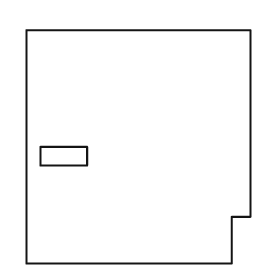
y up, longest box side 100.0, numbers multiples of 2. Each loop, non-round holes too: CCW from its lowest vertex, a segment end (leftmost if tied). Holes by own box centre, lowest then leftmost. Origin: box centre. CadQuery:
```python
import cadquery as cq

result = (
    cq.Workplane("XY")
    .moveTo(-48.0, -50.0)
    .lineTo(40.0, -50.0)
    .lineTo(40.0, -30.0)
    .lineTo(48.0, -30.0)
    .lineTo(48.0, 50.0)
    .lineTo(-48.0, 50.0)
    .close()
    .moveTo(-42.0, -8.0)
    .lineTo(-22.0, -8.0)
    .lineTo(-22.0, 0.0)
    .lineTo(-42.0, 0.0)
    .close()
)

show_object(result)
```